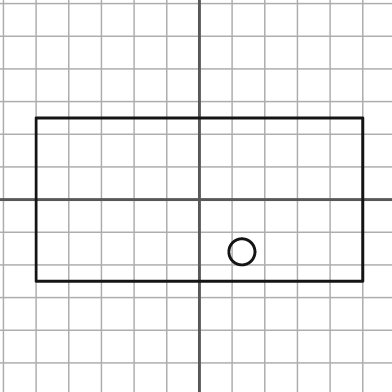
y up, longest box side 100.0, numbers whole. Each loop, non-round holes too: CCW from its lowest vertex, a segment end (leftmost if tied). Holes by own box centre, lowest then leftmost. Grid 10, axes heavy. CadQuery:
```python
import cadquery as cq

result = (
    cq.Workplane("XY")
    .moveTo(-50.0, -25.0)
    .lineTo(50.0, -25.0)
    .lineTo(50.0, 25.0)
    .lineTo(-50.0, 25.0)
    .close()
    .moveTo(13.0, -16.0)
    .circle(4.0)
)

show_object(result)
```